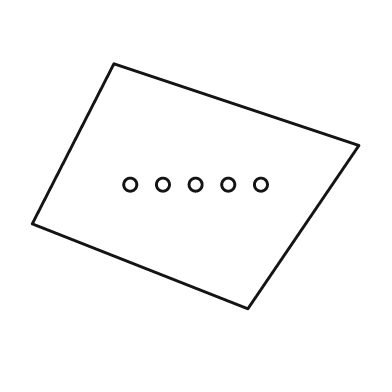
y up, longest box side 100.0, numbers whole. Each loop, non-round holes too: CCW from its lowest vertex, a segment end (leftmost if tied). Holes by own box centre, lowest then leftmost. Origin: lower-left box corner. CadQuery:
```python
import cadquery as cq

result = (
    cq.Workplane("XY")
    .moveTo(66.0, 0.0)
    .lineTo(100.0, 50.0)
    .lineTo(25.0, 75.0)
    .lineTo(0.0, 26.0)
    .close()
    .moveTo(30.0, 38.0)
    .circle(2.0)
    .moveTo(40.0, 38.0)
    .circle(2.0)
    .moveTo(50.0, 38.0)
    .circle(2.0)
    .moveTo(60.0, 38.0)
    .circle(2.0)
    .moveTo(70.0, 38.0)
    .circle(2.0)
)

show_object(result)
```